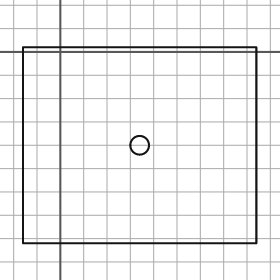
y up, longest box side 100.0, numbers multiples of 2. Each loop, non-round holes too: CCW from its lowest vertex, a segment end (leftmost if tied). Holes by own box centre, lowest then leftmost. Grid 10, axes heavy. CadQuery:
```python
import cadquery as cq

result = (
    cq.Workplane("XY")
    .moveTo(-16.0, -82.0)
    .lineTo(84.0, -82.0)
    .lineTo(84.0, 2.0)
    .lineTo(-16.0, 2.0)
    .close()
    .moveTo(34.0, -40.0)
    .circle(4.0)
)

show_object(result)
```